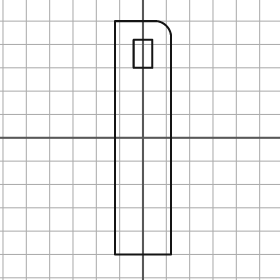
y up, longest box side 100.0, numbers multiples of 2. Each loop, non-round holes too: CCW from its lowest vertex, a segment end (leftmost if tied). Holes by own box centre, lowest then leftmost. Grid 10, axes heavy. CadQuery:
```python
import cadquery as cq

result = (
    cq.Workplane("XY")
    .moveTo(-12.0, -50.0)
    .lineTo(12.0, -50.0)
    .lineTo(12.0, 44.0)
    .threePointArc((10.0, 48.0), (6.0, 50.0))
    .lineTo(-12.0, 50.0)
    .close()
    .moveTo(-4.0, 30.0)
    .lineTo(4.0, 30.0)
    .lineTo(4.0, 42.0)
    .lineTo(-4.0, 42.0)
    .close()
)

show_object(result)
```